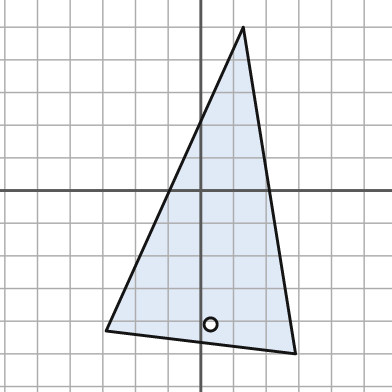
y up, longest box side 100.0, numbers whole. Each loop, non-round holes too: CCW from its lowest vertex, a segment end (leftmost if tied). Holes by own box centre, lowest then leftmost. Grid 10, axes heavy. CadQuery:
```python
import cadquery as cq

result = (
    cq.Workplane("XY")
    .moveTo(29.0, -50.0)
    .lineTo(13.0, 50.0)
    .lineTo(-29.0, -43.0)
    .close()
    .moveTo(3.0, -41.0)
    .circle(2.0)
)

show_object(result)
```